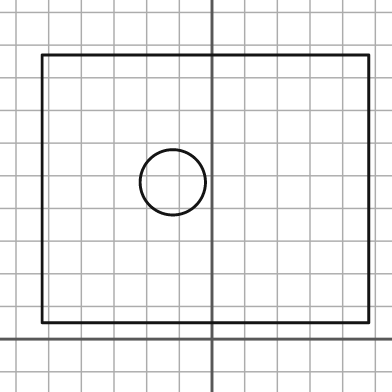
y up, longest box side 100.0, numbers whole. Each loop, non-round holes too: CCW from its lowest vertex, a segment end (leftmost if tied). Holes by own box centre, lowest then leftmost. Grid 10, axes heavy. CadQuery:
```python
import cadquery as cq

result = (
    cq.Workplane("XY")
    .moveTo(-52.0, 5.0)
    .lineTo(48.0, 5.0)
    .lineTo(48.0, 87.0)
    .lineTo(-52.0, 87.0)
    .close()
    .moveTo(-12.0, 48.0)
    .circle(10.0)
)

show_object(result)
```